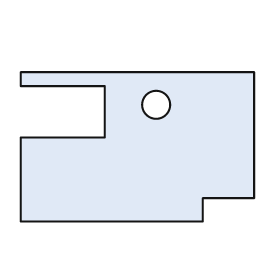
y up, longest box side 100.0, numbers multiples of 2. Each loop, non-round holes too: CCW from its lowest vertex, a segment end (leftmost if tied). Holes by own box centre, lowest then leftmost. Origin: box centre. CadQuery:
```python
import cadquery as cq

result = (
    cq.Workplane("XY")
    .moveTo(-50.0, -32.0)
    .lineTo(28.0, -32.0)
    .lineTo(28.0, -22.0)
    .lineTo(50.0, -22.0)
    .lineTo(50.0, 32.0)
    .lineTo(-50.0, 32.0)
    .lineTo(-50.0, 26.0)
    .lineTo(-14.0, 26.0)
    .lineTo(-14.0, 4.0)
    .lineTo(-50.0, 4.0)
    .close()
    .moveTo(8.0, 18.0)
    .circle(6.0)
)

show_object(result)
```